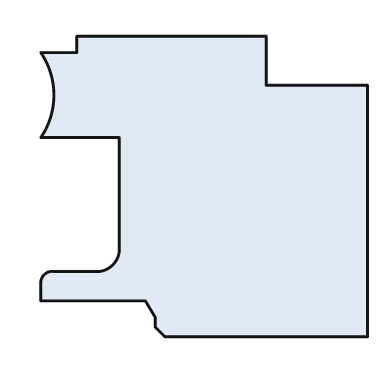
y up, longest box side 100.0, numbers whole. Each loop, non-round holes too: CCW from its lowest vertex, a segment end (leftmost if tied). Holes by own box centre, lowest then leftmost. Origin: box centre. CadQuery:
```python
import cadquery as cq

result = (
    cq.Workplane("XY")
    .moveTo(-12.0, -46.0)
    .lineTo(50.0, -46.0)
    .lineTo(50.0, 31.0)
    .lineTo(19.0, 31.0)
    .lineTo(19.0, 46.0)
    .lineTo(-39.0, 46.0)
    .lineTo(-39.0, 41.0)
    .lineTo(-50.0, 41.0)
    .threePointArc((-46.0, 28.0), (-50.0, 15.0))
    .lineTo(-26.0, 15.0)
    .lineTo(-26.0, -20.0)
    .threePointArc((-28.0, -24.0), (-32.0, -26.0))
    .lineTo(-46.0, -26.0)
    .threePointArc((-49.0, -27.0), (-50.0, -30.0))
    .lineTo(-50.0, -35.0)
    .lineTo(-18.0, -35.0)
    .lineTo(-15.0, -40.0)
    .lineTo(-15.0, -43.0)
    .close()
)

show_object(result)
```